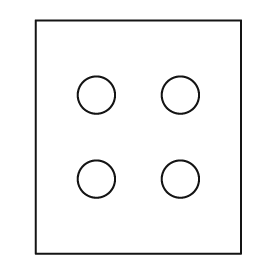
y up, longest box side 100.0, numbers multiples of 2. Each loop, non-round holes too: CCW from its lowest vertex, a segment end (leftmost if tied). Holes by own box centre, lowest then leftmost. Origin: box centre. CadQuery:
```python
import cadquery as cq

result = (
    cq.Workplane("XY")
    .moveTo(-44.0, -50.0)
    .lineTo(44.0, -50.0)
    .lineTo(44.0, 50.0)
    .lineTo(-44.0, 50.0)
    .close()
    .moveTo(-18.0, -18.0)
    .circle(8.0)
    .moveTo(18.0, -18.0)
    .circle(8.0)
    .moveTo(-18.0, 18.0)
    .circle(8.0)
    .moveTo(18.0, 18.0)
    .circle(8.0)
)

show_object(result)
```